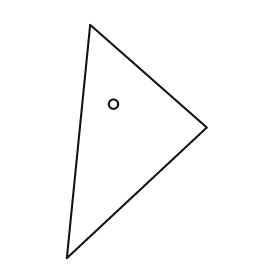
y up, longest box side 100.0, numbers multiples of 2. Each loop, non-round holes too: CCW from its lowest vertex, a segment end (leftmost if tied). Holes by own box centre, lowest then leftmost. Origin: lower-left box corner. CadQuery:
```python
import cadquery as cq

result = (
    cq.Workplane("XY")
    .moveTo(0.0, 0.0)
    .lineTo(60.0, 56.0)
    .lineTo(10.0, 100.0)
    .close()
    .moveTo(20.0, 66.0)
    .circle(2.0)
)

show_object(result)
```